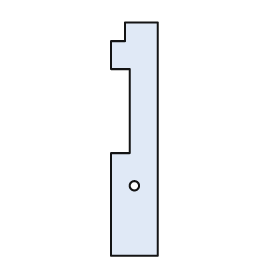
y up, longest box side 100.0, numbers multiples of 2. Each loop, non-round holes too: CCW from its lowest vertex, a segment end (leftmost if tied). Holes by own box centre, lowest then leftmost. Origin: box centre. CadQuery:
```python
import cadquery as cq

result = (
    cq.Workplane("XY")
    .moveTo(-10.0, -50.0)
    .lineTo(10.0, -50.0)
    .lineTo(10.0, 50.0)
    .lineTo(-4.0, 50.0)
    .lineTo(-4.0, 42.0)
    .lineTo(-10.0, 42.0)
    .lineTo(-10.0, 30.0)
    .lineTo(-2.0, 30.0)
    .lineTo(-2.0, -6.0)
    .lineTo(-10.0, -6.0)
    .close()
    .moveTo(0.0, -20.0)
    .circle(2.0)
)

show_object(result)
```